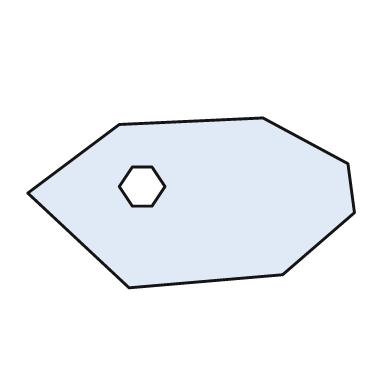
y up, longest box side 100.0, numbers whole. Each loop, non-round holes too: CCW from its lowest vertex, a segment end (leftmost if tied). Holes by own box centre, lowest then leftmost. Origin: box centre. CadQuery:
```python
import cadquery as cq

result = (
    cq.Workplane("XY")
    .moveTo(-19.0, -26.0)
    .lineTo(28.0, -22.0)
    .lineTo(50.0, -3.0)
    .lineTo(48.0, 12.0)
    .lineTo(22.0, 26.0)
    .lineTo(-22.0, 24.0)
    .lineTo(-50.0, 3.0)
    .close()
    .moveTo(-18.0, -1.0)
    .lineTo(-12.0, -1.0)
    .lineTo(-8.0, 5.0)
    .lineTo(-12.0, 11.0)
    .lineTo(-18.0, 11.0)
    .lineTo(-22.0, 5.0)
    .close()
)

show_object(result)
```